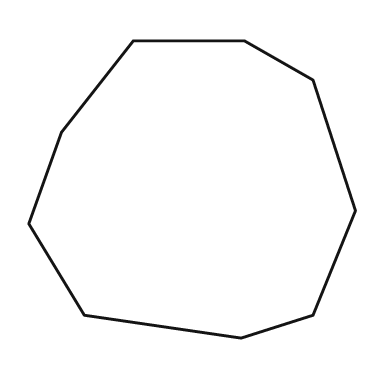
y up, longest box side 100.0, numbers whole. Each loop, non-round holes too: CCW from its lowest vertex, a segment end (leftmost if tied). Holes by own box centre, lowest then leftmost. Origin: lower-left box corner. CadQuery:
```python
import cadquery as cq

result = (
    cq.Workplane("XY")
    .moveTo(65.0, 0.0)
    .lineTo(87.0, 7.0)
    .lineTo(100.0, 39.0)
    .lineTo(87.0, 79.0)
    .lineTo(66.0, 91.0)
    .lineTo(32.0, 91.0)
    .lineTo(10.0, 63.0)
    .lineTo(0.0, 35.0)
    .lineTo(17.0, 7.0)
    .close()
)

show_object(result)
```